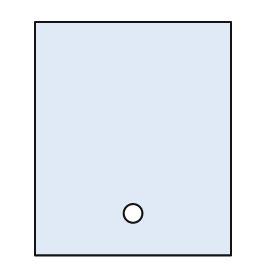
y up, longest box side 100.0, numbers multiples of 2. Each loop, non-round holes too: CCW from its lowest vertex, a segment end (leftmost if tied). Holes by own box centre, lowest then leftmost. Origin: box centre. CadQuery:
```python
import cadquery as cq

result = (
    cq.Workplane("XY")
    .moveTo(-42.0, -50.0)
    .lineTo(42.0, -50.0)
    .lineTo(42.0, 50.0)
    .lineTo(-42.0, 50.0)
    .close()
    .moveTo(0.0, -32.0)
    .circle(4.0)
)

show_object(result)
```